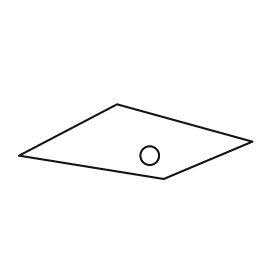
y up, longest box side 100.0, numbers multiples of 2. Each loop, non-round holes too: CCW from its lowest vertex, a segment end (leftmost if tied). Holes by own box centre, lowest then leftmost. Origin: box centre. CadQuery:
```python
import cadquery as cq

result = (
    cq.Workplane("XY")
    .moveTo(12.0, -16.0)
    .lineTo(50.0, 0.0)
    .lineTo(-8.0, 16.0)
    .lineTo(-50.0, -6.0)
    .close()
    .moveTo(6.0, -6.0)
    .circle(4.0)
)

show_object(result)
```